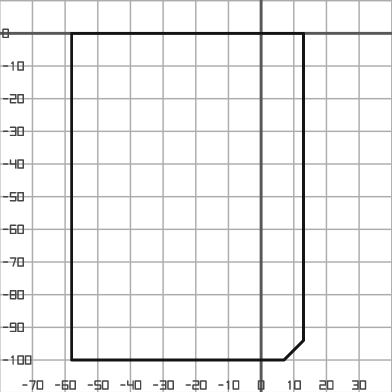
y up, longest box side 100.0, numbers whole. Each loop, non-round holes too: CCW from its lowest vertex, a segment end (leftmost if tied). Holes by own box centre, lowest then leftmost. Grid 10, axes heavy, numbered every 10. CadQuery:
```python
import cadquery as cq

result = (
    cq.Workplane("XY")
    .moveTo(-58.0, -100.0)
    .lineTo(7.0, -100.0)
    .lineTo(13.0, -94.0)
    .lineTo(13.0, 0.0)
    .lineTo(-58.0, 0.0)
    .close()
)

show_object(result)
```